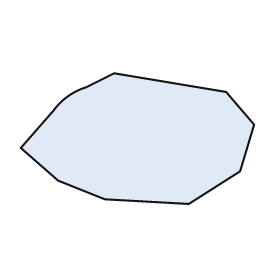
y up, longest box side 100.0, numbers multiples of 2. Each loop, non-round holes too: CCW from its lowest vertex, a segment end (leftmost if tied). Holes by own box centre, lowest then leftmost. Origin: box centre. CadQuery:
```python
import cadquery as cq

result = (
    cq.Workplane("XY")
    .moveTo(22.0, -28.0)
    .lineTo(44.0, -14.0)
    .lineTo(50.0, 6.0)
    .lineTo(38.0, 20.0)
    .lineTo(-10.0, 28.0)
    .lineTo(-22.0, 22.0)
    .threePointArc((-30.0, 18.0), (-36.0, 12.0))
    .lineTo(-50.0, -4.0)
    .lineTo(-34.0, -18.0)
    .lineTo(-14.0, -26.0)
    .close()
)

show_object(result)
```